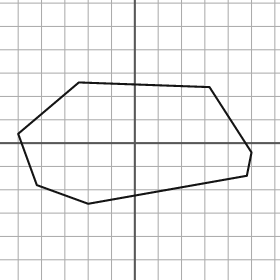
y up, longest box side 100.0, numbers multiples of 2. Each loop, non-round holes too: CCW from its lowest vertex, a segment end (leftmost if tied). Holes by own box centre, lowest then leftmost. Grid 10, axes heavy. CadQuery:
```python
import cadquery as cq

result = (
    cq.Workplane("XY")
    .moveTo(-20.0, -26.0)
    .lineTo(48.0, -14.0)
    .lineTo(50.0, -4.0)
    .lineTo(32.0, 24.0)
    .lineTo(-24.0, 26.0)
    .lineTo(-50.0, 4.0)
    .lineTo(-42.0, -18.0)
    .close()
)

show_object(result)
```